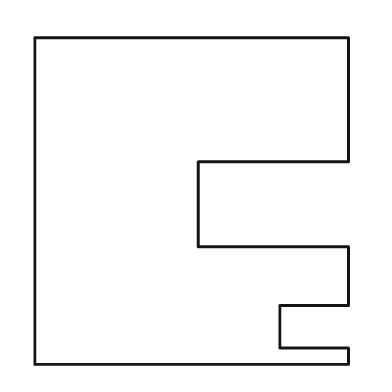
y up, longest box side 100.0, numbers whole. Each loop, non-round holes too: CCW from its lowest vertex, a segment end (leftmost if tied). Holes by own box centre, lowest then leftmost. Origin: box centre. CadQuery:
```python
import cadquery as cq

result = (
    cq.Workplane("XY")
    .moveTo(-48.0, -50.0)
    .lineTo(48.0, -50.0)
    .lineTo(48.0, -45.0)
    .lineTo(27.0, -45.0)
    .lineTo(27.0, -32.0)
    .lineTo(48.0, -32.0)
    .lineTo(48.0, -14.0)
    .lineTo(2.0, -14.0)
    .lineTo(2.0, 12.0)
    .lineTo(48.0, 12.0)
    .lineTo(48.0, 50.0)
    .lineTo(-48.0, 50.0)
    .close()
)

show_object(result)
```